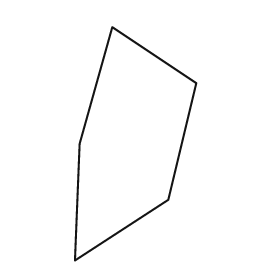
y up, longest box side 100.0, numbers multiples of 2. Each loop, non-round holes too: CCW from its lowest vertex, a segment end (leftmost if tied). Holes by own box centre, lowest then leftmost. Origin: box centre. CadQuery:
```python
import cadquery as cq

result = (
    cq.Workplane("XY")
    .moveTo(-26.0, -50.0)
    .lineTo(14.0, -24.0)
    .lineTo(26.0, 26.0)
    .lineTo(-10.0, 50.0)
    .lineTo(-24.0, 0.0)
    .close()
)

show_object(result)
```